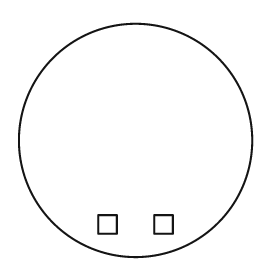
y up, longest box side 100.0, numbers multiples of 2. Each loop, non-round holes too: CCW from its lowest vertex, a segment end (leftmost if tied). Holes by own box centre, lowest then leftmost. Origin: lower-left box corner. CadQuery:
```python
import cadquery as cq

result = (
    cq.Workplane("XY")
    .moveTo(50.0, 50.0)
    .circle(50.0)
    .moveTo(34.0, 10.0)
    .lineTo(42.0, 10.0)
    .lineTo(42.0, 18.0)
    .lineTo(34.0, 18.0)
    .close()
    .moveTo(58.0, 10.0)
    .lineTo(66.0, 10.0)
    .lineTo(66.0, 18.0)
    .lineTo(58.0, 18.0)
    .close()
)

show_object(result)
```